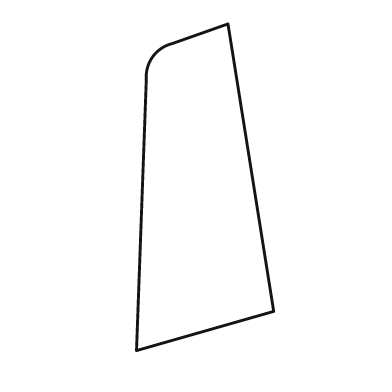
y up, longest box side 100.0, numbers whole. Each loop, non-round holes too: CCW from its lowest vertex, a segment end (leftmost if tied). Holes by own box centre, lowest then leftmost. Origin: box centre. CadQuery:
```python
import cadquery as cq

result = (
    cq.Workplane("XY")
    .moveTo(-21.0, -50.0)
    .lineTo(21.0, -38.0)
    .lineTo(7.0, 50.0)
    .lineTo(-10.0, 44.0)
    .threePointArc((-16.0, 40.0), (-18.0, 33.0))
    .close()
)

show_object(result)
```